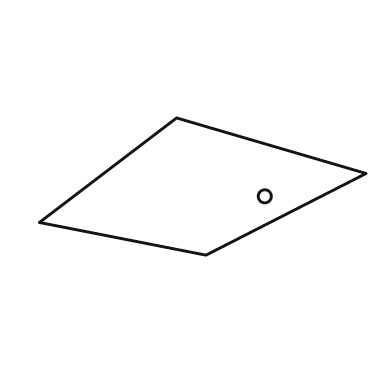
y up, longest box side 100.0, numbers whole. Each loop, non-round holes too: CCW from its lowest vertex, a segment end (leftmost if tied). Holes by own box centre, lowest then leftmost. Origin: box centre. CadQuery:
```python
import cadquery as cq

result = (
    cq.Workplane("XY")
    .moveTo(1.0, -21.0)
    .lineTo(50.0, 4.0)
    .lineTo(-8.0, 21.0)
    .lineTo(-50.0, -11.0)
    .close()
    .moveTo(19.0, -3.0)
    .circle(2.0)
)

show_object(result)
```